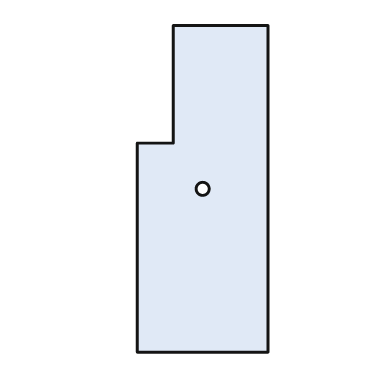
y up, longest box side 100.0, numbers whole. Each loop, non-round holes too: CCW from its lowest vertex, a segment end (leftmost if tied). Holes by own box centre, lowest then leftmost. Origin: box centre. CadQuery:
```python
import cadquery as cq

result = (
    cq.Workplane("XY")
    .moveTo(-20.0, -50.0)
    .lineTo(20.0, -50.0)
    .lineTo(20.0, 50.0)
    .lineTo(-9.0, 50.0)
    .lineTo(-9.0, 14.0)
    .lineTo(-20.0, 14.0)
    .close()
    .moveTo(0.0, 0.0)
    .circle(2.0)
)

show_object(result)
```